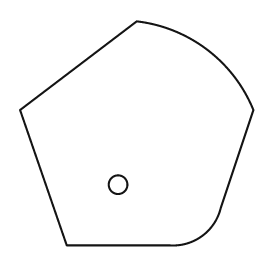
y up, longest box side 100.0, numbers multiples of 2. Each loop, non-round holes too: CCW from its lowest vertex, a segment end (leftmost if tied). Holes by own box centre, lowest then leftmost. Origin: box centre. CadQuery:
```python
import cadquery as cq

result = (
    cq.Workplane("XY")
    .moveTo(-30.0, -48.0)
    .lineTo(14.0, -48.0)
    .threePointArc((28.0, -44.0), (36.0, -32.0))
    .lineTo(50.0, 10.0)
    .threePointArc((30.0, 36.0), (0.0, 48.0))
    .lineTo(-50.0, 10.0)
    .close()
    .moveTo(-8.0, -22.0)
    .circle(4.0)
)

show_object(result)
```